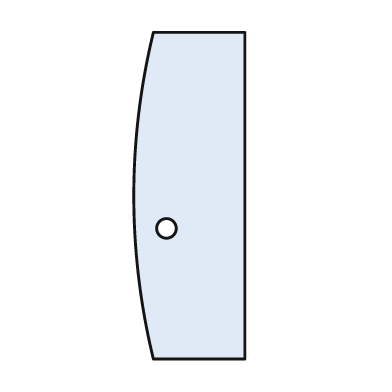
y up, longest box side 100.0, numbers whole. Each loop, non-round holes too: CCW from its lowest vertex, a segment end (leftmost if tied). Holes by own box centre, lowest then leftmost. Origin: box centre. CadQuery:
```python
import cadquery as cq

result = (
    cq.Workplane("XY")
    .moveTo(-11.0, -50.0)
    .lineTo(17.0, -50.0)
    .lineTo(17.0, 50.0)
    .lineTo(-11.0, 50.0)
    .threePointArc((-17.0, 0.0), (-11.0, -50.0))
    .close()
    .moveTo(-7.0, -10.0)
    .circle(3.0)
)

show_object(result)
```